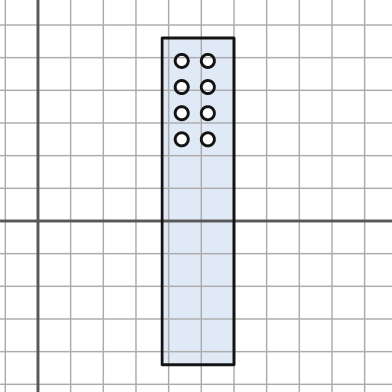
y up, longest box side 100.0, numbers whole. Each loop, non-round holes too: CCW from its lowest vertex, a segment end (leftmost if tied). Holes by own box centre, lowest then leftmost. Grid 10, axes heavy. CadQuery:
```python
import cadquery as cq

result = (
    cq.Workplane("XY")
    .moveTo(38.0, -44.0)
    .lineTo(60.0, -44.0)
    .lineTo(60.0, 56.0)
    .lineTo(38.0, 56.0)
    .close()
    .moveTo(44.0, 25.0)
    .circle(2.0)
    .moveTo(52.0, 25.0)
    .circle(2.0)
    .moveTo(44.0, 33.0)
    .circle(2.0)
    .moveTo(52.0, 33.0)
    .circle(2.0)
    .moveTo(44.0, 41.0)
    .circle(2.0)
    .moveTo(52.0, 41.0)
    .circle(2.0)
    .moveTo(44.0, 49.0)
    .circle(2.0)
    .moveTo(52.0, 49.0)
    .circle(2.0)
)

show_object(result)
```